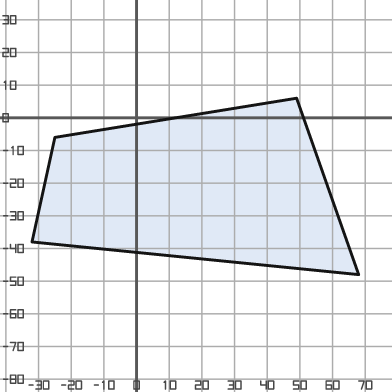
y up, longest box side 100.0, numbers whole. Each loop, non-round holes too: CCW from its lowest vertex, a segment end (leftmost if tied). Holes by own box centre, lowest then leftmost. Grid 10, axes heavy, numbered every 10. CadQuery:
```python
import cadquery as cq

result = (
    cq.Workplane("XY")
    .moveTo(68.0, -48.0)
    .lineTo(49.0, 6.0)
    .lineTo(-25.0, -6.0)
    .lineTo(-32.0, -38.0)
    .close()
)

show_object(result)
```